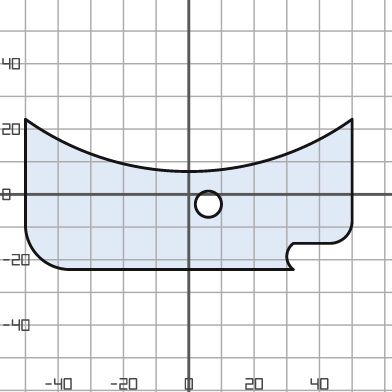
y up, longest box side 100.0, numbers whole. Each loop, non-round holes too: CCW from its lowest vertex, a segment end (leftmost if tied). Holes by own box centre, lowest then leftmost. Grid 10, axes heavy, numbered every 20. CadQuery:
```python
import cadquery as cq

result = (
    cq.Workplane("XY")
    .moveTo(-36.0, -23.0)
    .lineTo(32.0, -23.0)
    .threePointArc((30.0, -19.0), (32.0, -15.0))
    .lineTo(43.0, -15.0)
    .threePointArc((48.0, -13.0), (50.0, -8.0))
    .lineTo(50.0, 23.0)
    .threePointArc((0.0, 7.0), (-50.0, 23.0))
    .lineTo(-50.0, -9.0)
    .threePointArc((-46.0, -19.0), (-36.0, -23.0))
    .close()
    .moveTo(6.0, -3.0)
    .circle(4.0)
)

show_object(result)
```